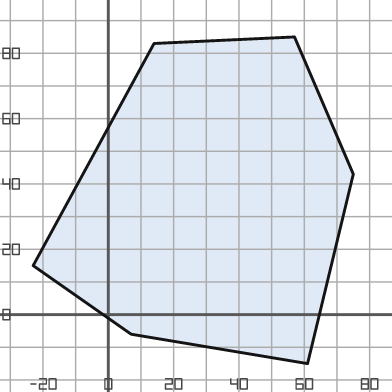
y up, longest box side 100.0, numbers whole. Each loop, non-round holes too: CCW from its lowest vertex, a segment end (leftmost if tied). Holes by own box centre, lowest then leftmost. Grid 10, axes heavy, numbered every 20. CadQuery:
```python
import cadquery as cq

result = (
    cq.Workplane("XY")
    .moveTo(61.0, -15.0)
    .lineTo(75.0, 43.0)
    .lineTo(57.0, 85.0)
    .lineTo(14.0, 83.0)
    .lineTo(-23.0, 15.0)
    .lineTo(7.0, -6.0)
    .close()
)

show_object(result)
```